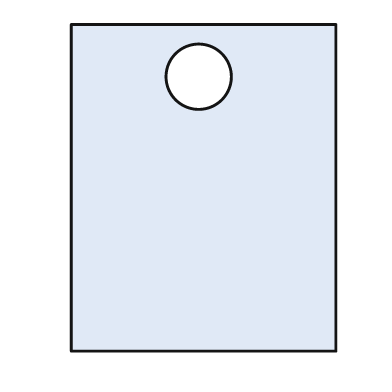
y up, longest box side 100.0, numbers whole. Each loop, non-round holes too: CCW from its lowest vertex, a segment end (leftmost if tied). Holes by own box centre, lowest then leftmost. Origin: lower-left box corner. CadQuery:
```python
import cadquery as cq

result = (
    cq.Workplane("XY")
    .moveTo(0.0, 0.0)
    .lineTo(81.0, 0.0)
    .lineTo(81.0, 100.0)
    .lineTo(0.0, 100.0)
    .close()
    .moveTo(39.0, 84.0)
    .circle(10.0)
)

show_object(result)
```